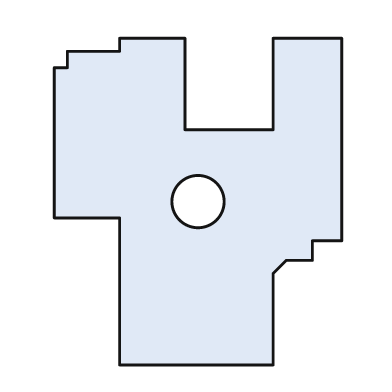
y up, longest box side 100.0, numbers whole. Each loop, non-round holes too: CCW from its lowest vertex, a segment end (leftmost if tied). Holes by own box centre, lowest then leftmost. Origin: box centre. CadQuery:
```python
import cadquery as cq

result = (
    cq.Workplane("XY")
    .moveTo(-24.0, -50.0)
    .lineTo(23.0, -50.0)
    .lineTo(23.0, -22.0)
    .lineTo(27.0, -18.0)
    .lineTo(35.0, -18.0)
    .lineTo(35.0, -12.0)
    .lineTo(44.0, -12.0)
    .lineTo(44.0, 50.0)
    .lineTo(23.0, 50.0)
    .lineTo(23.0, 22.0)
    .lineTo(-4.0, 22.0)
    .lineTo(-4.0, 50.0)
    .lineTo(-24.0, 50.0)
    .lineTo(-24.0, 46.0)
    .lineTo(-40.0, 46.0)
    .lineTo(-40.0, 41.0)
    .lineTo(-44.0, 41.0)
    .lineTo(-44.0, -5.0)
    .lineTo(-24.0, -5.0)
    .close()
    .moveTo(0.0, 0.0)
    .circle(8.0)
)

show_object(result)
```